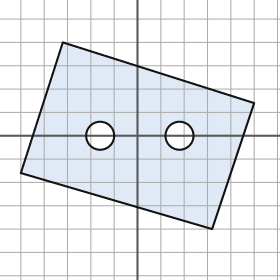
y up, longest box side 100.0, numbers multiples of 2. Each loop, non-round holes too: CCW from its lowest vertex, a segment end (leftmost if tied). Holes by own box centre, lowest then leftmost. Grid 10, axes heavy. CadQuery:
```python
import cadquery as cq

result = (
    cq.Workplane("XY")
    .moveTo(32.0, -40.0)
    .lineTo(50.0, 14.0)
    .lineTo(-32.0, 40.0)
    .lineTo(-50.0, -16.0)
    .close()
    .moveTo(-16.0, 0.0)
    .circle(6.0)
    .moveTo(18.0, 0.0)
    .circle(6.0)
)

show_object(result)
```